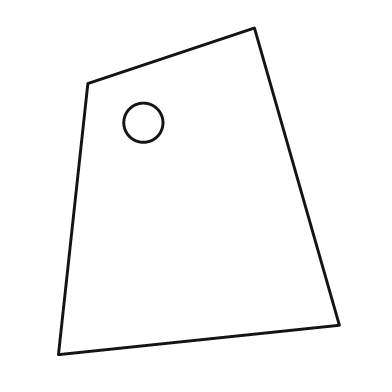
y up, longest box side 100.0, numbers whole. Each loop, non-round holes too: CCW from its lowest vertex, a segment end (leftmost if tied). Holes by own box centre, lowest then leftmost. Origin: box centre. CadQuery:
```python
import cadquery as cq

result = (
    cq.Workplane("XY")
    .moveTo(-43.0, -50.0)
    .lineTo(43.0, -41.0)
    .lineTo(17.0, 50.0)
    .lineTo(-34.0, 33.0)
    .close()
    .moveTo(-17.0, 21.0)
    .circle(6.0)
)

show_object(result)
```